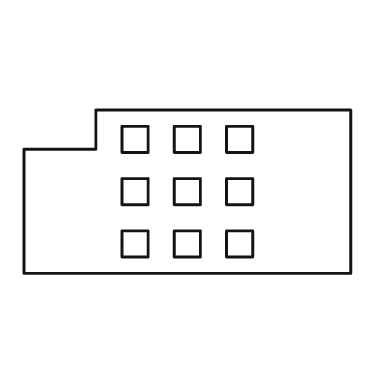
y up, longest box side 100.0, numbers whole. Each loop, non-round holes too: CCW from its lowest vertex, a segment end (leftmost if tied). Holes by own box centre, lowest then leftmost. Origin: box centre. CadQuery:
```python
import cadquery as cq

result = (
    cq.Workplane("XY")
    .moveTo(-50.0, -25.0)
    .lineTo(50.0, -25.0)
    .lineTo(50.0, 25.0)
    .lineTo(-28.0, 25.0)
    .lineTo(-28.0, 13.0)
    .lineTo(-50.0, 13.0)
    .close()
    .moveTo(-20.0, -20.0)
    .lineTo(-12.0, -20.0)
    .lineTo(-12.0, -12.0)
    .lineTo(-20.0, -12.0)
    .close()
    .moveTo(-4.0, -20.0)
    .lineTo(4.0, -20.0)
    .lineTo(4.0, -12.0)
    .lineTo(-4.0, -12.0)
    .close()
    .moveTo(12.0, -20.0)
    .lineTo(20.0, -20.0)
    .lineTo(20.0, -12.0)
    .lineTo(12.0, -12.0)
    .close()
    .moveTo(-20.0, -4.0)
    .lineTo(-12.0, -4.0)
    .lineTo(-12.0, 4.0)
    .lineTo(-20.0, 4.0)
    .close()
    .moveTo(-4.0, -4.0)
    .lineTo(4.0, -4.0)
    .lineTo(4.0, 4.0)
    .lineTo(-4.0, 4.0)
    .close()
    .moveTo(12.0, -4.0)
    .lineTo(20.0, -4.0)
    .lineTo(20.0, 4.0)
    .lineTo(12.0, 4.0)
    .close()
    .moveTo(-20.0, 12.0)
    .lineTo(-12.0, 12.0)
    .lineTo(-12.0, 20.0)
    .lineTo(-20.0, 20.0)
    .close()
    .moveTo(-4.0, 12.0)
    .lineTo(4.0, 12.0)
    .lineTo(4.0, 20.0)
    .lineTo(-4.0, 20.0)
    .close()
    .moveTo(12.0, 12.0)
    .lineTo(20.0, 12.0)
    .lineTo(20.0, 20.0)
    .lineTo(12.0, 20.0)
    .close()
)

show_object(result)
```